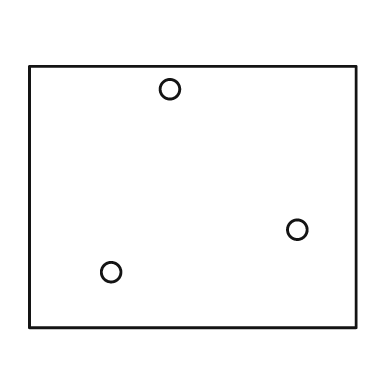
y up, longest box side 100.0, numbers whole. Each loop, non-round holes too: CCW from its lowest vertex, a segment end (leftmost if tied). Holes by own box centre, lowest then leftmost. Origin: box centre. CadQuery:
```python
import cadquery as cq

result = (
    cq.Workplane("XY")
    .moveTo(-50.0, -40.0)
    .lineTo(50.0, -40.0)
    .lineTo(50.0, 40.0)
    .lineTo(-50.0, 40.0)
    .close()
    .moveTo(-25.0, -23.0)
    .circle(3.0)
    .moveTo(32.0, -10.0)
    .circle(3.0)
    .moveTo(-7.0, 33.0)
    .circle(3.0)
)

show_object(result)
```